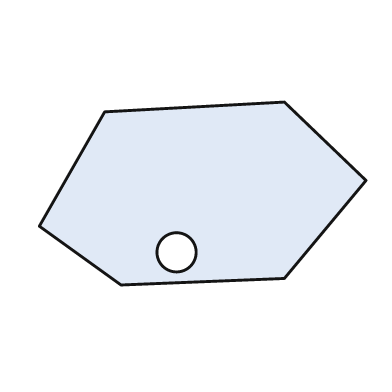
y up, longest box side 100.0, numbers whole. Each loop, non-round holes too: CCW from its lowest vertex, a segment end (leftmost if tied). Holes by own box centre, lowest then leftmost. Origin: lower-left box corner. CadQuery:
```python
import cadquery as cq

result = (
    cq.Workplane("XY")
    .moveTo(25.0, 0.0)
    .lineTo(75.0, 2.0)
    .lineTo(100.0, 32.0)
    .lineTo(75.0, 56.0)
    .lineTo(20.0, 53.0)
    .lineTo(0.0, 18.0)
    .close()
    .moveTo(42.0, 10.0)
    .circle(6.0)
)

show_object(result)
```